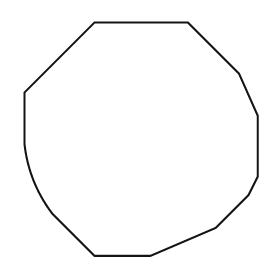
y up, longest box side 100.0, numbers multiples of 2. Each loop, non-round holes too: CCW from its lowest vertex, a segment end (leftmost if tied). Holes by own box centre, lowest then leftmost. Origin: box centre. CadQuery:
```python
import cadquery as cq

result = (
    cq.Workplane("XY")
    .moveTo(-20.0, -50.0)
    .lineTo(4.0, -50.0)
    .lineTo(32.0, -38.0)
    .lineTo(46.0, -24.0)
    .lineTo(50.0, -16.0)
    .lineTo(50.0, 10.0)
    .lineTo(42.0, 28.0)
    .lineTo(20.0, 50.0)
    .lineTo(-20.0, 50.0)
    .lineTo(-50.0, 20.0)
    .lineTo(-50.0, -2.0)
    .threePointArc((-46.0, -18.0), (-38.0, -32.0))
    .close()
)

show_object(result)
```